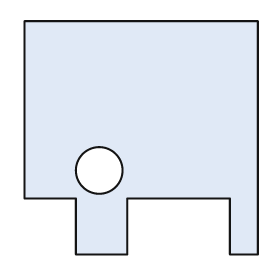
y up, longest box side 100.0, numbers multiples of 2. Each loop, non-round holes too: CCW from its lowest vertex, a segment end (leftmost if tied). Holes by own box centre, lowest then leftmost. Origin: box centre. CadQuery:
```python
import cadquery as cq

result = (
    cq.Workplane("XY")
    .moveTo(-28.0, -50.0)
    .lineTo(-6.0, -50.0)
    .lineTo(-6.0, -26.0)
    .lineTo(38.0, -26.0)
    .lineTo(38.0, -50.0)
    .lineTo(50.0, -50.0)
    .lineTo(50.0, 50.0)
    .lineTo(-50.0, 50.0)
    .lineTo(-50.0, -26.0)
    .lineTo(-28.0, -26.0)
    .close()
    .moveTo(-18.0, -14.0)
    .circle(10.0)
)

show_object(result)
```